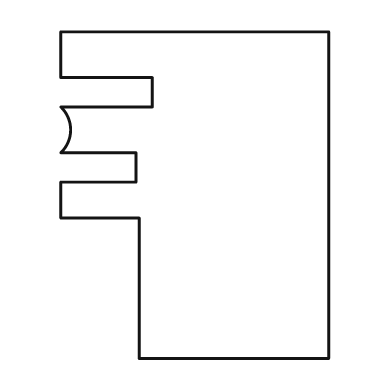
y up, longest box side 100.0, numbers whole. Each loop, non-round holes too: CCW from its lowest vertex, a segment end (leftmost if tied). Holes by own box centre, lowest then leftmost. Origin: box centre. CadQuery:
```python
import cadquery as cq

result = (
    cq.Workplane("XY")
    .moveTo(-17.0, -50.0)
    .lineTo(41.0, -50.0)
    .lineTo(41.0, 50.0)
    .lineTo(-41.0, 50.0)
    .lineTo(-41.0, 36.0)
    .lineTo(-13.0, 36.0)
    .lineTo(-13.0, 27.0)
    .lineTo(-41.0, 27.0)
    .threePointArc((-38.0, 20.0), (-41.0, 13.0))
    .lineTo(-18.0, 13.0)
    .lineTo(-18.0, 4.0)
    .lineTo(-41.0, 4.0)
    .lineTo(-41.0, -7.0)
    .lineTo(-17.0, -7.0)
    .close()
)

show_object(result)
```